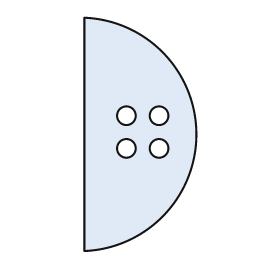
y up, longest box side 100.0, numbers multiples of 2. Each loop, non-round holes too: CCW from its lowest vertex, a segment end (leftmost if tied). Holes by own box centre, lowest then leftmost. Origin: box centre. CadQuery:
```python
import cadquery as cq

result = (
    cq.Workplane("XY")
    .moveTo(-24.0, -50.0)
    .threePointArc((24.0, 0.0), (-24.0, 50.0))
    .close()
    .moveTo(-6.0, -6.0)
    .circle(4.0)
    .moveTo(8.0, -6.0)
    .circle(4.0)
    .moveTo(-6.0, 8.0)
    .circle(4.0)
    .moveTo(8.0, 8.0)
    .circle(4.0)
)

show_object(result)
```